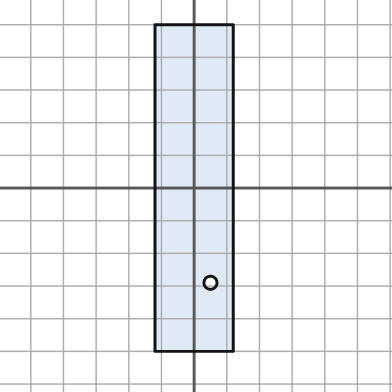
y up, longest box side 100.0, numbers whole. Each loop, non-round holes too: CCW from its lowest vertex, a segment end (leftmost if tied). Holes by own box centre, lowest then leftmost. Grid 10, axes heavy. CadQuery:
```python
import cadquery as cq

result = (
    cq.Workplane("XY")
    .moveTo(-12.0, -50.0)
    .lineTo(12.0, -50.0)
    .lineTo(12.0, 50.0)
    .lineTo(-12.0, 50.0)
    .close()
    .moveTo(5.0, -29.0)
    .circle(2.0)
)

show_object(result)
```